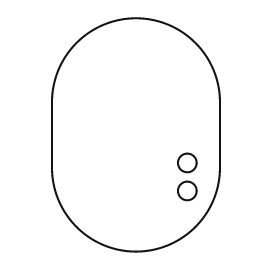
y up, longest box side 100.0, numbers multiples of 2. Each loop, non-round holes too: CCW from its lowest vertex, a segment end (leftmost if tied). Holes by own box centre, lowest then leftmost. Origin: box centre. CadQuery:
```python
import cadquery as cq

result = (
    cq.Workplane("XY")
    .moveTo(-36.0, -14.0)
    .threePointArc((0.0, -50.0), (36.0, -14.0))
    .lineTo(36.0, 14.0)
    .threePointArc((0.0, 50.0), (-36.0, 14.0))
    .close()
    .moveTo(22.0, -24.0)
    .circle(4.0)
    .moveTo(22.0, -12.0)
    .circle(4.0)
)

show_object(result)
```